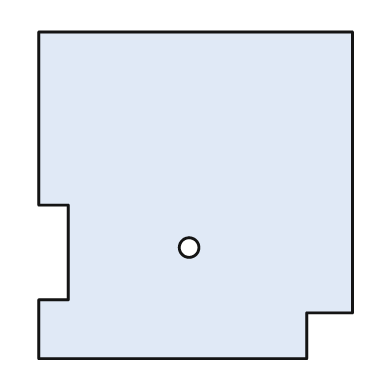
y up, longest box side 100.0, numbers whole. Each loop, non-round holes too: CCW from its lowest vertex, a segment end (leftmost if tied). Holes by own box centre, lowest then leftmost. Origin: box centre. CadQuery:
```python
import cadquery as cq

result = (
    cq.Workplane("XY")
    .moveTo(-48.0, -50.0)
    .lineTo(34.0, -50.0)
    .lineTo(34.0, -36.0)
    .lineTo(48.0, -36.0)
    .lineTo(48.0, 50.0)
    .lineTo(-48.0, 50.0)
    .lineTo(-48.0, -3.0)
    .lineTo(-39.0, -3.0)
    .lineTo(-39.0, -32.0)
    .lineTo(-48.0, -32.0)
    .close()
    .moveTo(-2.0, -16.0)
    .circle(3.0)
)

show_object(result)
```